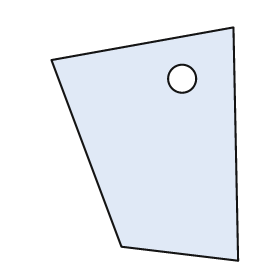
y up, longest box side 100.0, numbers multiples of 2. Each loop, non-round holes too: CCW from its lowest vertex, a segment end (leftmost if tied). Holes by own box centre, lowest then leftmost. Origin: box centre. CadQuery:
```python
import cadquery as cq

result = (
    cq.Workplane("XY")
    .moveTo(40.0, -50.0)
    .lineTo(38.0, 50.0)
    .lineTo(-40.0, 36.0)
    .lineTo(-10.0, -44.0)
    .close()
    .moveTo(16.0, 28.0)
    .circle(6.0)
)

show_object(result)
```